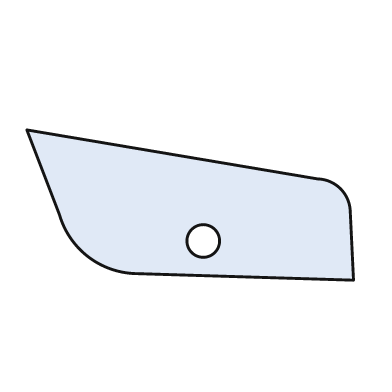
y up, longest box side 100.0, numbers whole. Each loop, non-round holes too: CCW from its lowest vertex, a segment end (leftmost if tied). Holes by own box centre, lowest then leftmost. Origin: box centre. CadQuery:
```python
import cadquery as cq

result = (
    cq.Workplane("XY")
    .moveTo(50.0, -23.0)
    .lineTo(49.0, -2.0)
    .threePointArc((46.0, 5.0), (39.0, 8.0))
    .lineTo(-50.0, 23.0)
    .lineTo(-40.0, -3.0)
    .threePointArc((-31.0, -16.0), (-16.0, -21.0))
    .close()
    .moveTo(4.0, -11.0)
    .circle(5.0)
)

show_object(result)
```